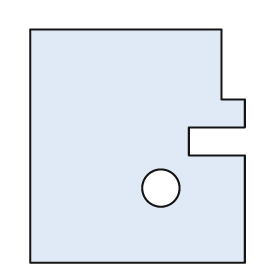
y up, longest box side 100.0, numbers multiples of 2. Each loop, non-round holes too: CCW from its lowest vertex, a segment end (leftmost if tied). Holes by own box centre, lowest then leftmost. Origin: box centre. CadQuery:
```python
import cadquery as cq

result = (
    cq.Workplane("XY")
    .moveTo(-46.0, -50.0)
    .lineTo(46.0, -50.0)
    .lineTo(46.0, -4.0)
    .lineTo(22.0, -4.0)
    .lineTo(22.0, 8.0)
    .lineTo(46.0, 8.0)
    .lineTo(46.0, 20.0)
    .lineTo(36.0, 20.0)
    .lineTo(36.0, 50.0)
    .lineTo(-46.0, 50.0)
    .close()
    .moveTo(10.0, -18.0)
    .circle(8.0)
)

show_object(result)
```